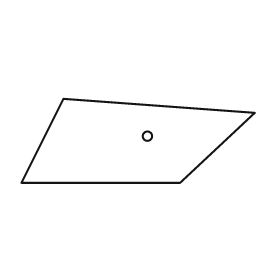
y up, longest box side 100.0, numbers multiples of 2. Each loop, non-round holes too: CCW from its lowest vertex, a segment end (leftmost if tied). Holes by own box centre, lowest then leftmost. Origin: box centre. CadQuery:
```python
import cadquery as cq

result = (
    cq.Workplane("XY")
    .moveTo(-50.0, -18.0)
    .lineTo(18.0, -18.0)
    .lineTo(50.0, 12.0)
    .lineTo(-32.0, 18.0)
    .close()
    .moveTo(4.0, 2.0)
    .circle(2.0)
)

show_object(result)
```